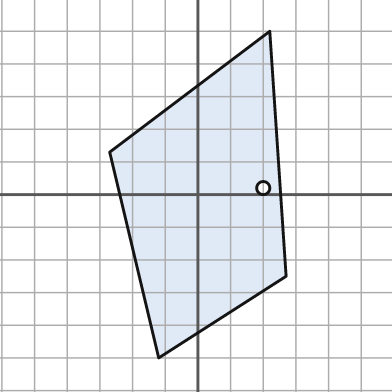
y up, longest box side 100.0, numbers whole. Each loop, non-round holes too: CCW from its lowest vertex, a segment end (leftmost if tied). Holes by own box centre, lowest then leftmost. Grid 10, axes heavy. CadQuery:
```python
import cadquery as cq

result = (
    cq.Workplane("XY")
    .moveTo(-12.0, -50.0)
    .lineTo(27.0, -25.0)
    .lineTo(22.0, 50.0)
    .lineTo(-27.0, 13.0)
    .close()
    .moveTo(20.0, 2.0)
    .circle(2.0)
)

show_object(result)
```